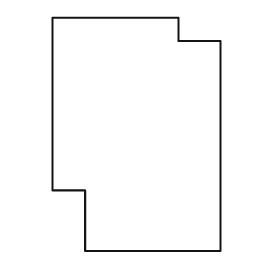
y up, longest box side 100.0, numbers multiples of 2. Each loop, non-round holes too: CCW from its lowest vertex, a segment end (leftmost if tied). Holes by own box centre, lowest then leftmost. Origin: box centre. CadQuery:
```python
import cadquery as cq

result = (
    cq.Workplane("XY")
    .moveTo(-22.0, -50.0)
    .lineTo(36.0, -50.0)
    .lineTo(36.0, 40.0)
    .lineTo(18.0, 40.0)
    .lineTo(18.0, 50.0)
    .lineTo(-36.0, 50.0)
    .lineTo(-36.0, -24.0)
    .lineTo(-22.0, -24.0)
    .close()
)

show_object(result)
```